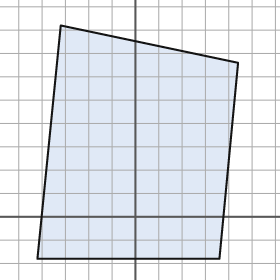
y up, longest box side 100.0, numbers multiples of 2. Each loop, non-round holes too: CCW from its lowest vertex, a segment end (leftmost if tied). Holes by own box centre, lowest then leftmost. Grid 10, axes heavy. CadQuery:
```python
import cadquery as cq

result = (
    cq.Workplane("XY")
    .moveTo(-42.0, -18.0)
    .lineTo(36.0, -18.0)
    .lineTo(44.0, 66.0)
    .lineTo(-32.0, 82.0)
    .close()
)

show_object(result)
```